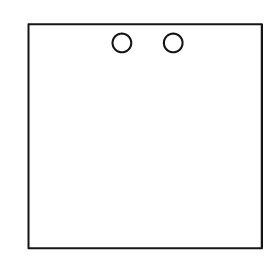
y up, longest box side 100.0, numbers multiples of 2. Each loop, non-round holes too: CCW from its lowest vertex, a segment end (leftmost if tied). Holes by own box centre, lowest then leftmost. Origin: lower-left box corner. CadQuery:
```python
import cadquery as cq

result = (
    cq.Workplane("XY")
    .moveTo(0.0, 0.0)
    .lineTo(100.0, 0.0)
    .lineTo(100.0, 96.0)
    .lineTo(0.0, 96.0)
    .close()
    .moveTo(40.0, 88.0)
    .circle(4.0)
    .moveTo(62.0, 88.0)
    .circle(4.0)
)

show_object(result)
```